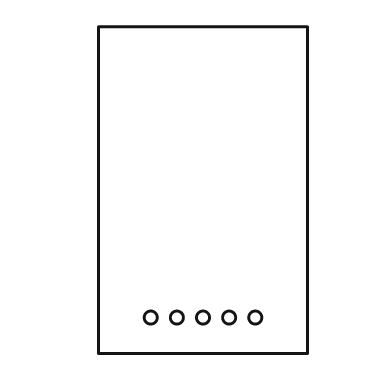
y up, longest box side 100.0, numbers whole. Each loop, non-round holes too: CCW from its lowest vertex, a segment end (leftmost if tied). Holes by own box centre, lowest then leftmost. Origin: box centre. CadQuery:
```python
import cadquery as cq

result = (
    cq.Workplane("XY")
    .moveTo(-32.0, -50.0)
    .lineTo(32.0, -50.0)
    .lineTo(32.0, 50.0)
    .lineTo(-32.0, 50.0)
    .close()
    .moveTo(-16.0, -39.0)
    .circle(2.0)
    .moveTo(-8.0, -39.0)
    .circle(2.0)
    .moveTo(0.0, -39.0)
    .circle(2.0)
    .moveTo(8.0, -39.0)
    .circle(2.0)
    .moveTo(16.0, -39.0)
    .circle(2.0)
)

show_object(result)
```